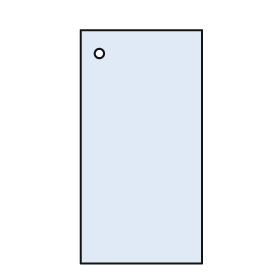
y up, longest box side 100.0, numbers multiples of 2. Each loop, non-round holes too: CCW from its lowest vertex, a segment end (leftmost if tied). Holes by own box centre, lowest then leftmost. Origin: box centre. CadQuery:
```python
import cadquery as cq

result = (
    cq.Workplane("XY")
    .moveTo(-26.0, -50.0)
    .lineTo(26.0, -50.0)
    .lineTo(26.0, 50.0)
    .lineTo(-26.0, 50.0)
    .close()
    .moveTo(-18.0, 40.0)
    .circle(2.0)
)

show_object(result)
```